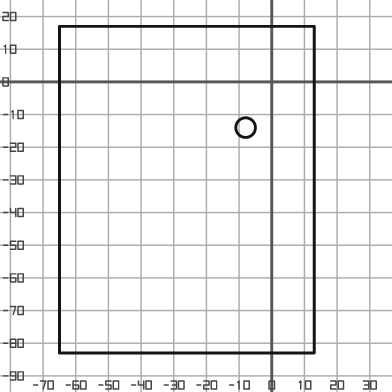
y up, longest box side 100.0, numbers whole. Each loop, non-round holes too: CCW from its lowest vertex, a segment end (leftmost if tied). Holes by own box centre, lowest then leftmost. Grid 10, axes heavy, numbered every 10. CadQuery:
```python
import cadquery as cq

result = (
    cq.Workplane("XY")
    .moveTo(-65.0, -83.0)
    .lineTo(13.0, -83.0)
    .lineTo(13.0, 17.0)
    .lineTo(-65.0, 17.0)
    .close()
    .moveTo(-8.0, -14.0)
    .circle(3.0)
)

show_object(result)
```